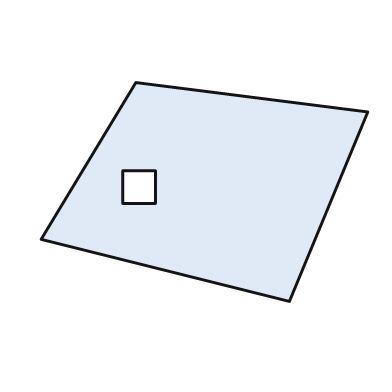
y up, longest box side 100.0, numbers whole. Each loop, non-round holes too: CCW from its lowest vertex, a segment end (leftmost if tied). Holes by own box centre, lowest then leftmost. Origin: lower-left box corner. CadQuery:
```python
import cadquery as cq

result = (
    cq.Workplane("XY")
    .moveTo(76.0, 0.0)
    .lineTo(100.0, 58.0)
    .lineTo(29.0, 67.0)
    .lineTo(0.0, 19.0)
    .close()
    .moveTo(25.0, 30.0)
    .lineTo(35.0, 30.0)
    .lineTo(35.0, 40.0)
    .lineTo(25.0, 40.0)
    .close()
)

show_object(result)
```